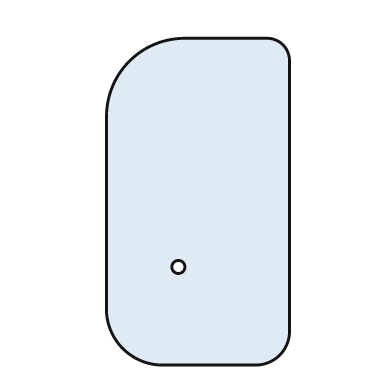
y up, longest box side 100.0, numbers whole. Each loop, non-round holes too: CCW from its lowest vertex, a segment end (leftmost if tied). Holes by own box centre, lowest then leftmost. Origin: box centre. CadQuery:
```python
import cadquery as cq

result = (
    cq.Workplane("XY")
    .moveTo(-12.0, -50.0)
    .lineTo(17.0, -50.0)
    .threePointArc((25.0, -47.0), (28.0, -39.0))
    .lineTo(28.0, 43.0)
    .threePointArc((26.0, 48.0), (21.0, 50.0))
    .lineTo(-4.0, 50.0)
    .threePointArc((-21.0, 43.0), (-28.0, 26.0))
    .lineTo(-28.0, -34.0)
    .threePointArc((-23.0, -45.0), (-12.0, -50.0))
    .close()
    .moveTo(-6.0, -20.0)
    .circle(2.0)
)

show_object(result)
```